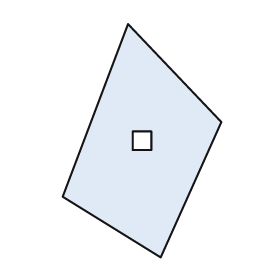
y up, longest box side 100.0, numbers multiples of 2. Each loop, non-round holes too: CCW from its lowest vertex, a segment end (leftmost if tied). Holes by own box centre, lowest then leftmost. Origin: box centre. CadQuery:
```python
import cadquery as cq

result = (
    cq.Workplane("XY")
    .moveTo(8.0, -50.0)
    .lineTo(34.0, 8.0)
    .lineTo(-6.0, 50.0)
    .lineTo(-34.0, -24.0)
    .close()
    .moveTo(-4.0, -4.0)
    .lineTo(4.0, -4.0)
    .lineTo(4.0, 4.0)
    .lineTo(-4.0, 4.0)
    .close()
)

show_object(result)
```